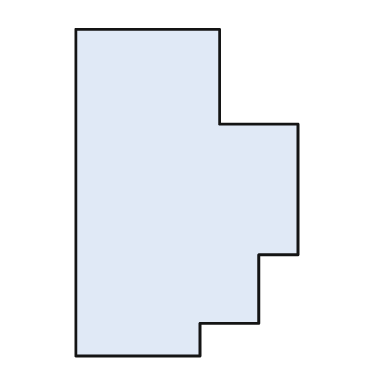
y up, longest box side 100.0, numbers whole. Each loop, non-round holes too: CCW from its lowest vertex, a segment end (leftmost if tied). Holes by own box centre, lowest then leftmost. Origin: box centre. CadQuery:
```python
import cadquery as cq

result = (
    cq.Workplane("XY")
    .moveTo(-34.0, -50.0)
    .lineTo(4.0, -50.0)
    .lineTo(4.0, -40.0)
    .lineTo(22.0, -40.0)
    .lineTo(22.0, -19.0)
    .lineTo(34.0, -19.0)
    .lineTo(34.0, 21.0)
    .lineTo(10.0, 21.0)
    .lineTo(10.0, 50.0)
    .lineTo(-34.0, 50.0)
    .close()
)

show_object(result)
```